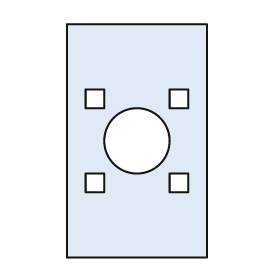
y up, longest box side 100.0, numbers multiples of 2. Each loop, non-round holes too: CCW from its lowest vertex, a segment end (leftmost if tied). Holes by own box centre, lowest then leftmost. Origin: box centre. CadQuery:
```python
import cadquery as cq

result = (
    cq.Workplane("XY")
    .moveTo(-30.0, -50.0)
    .lineTo(30.0, -50.0)
    .lineTo(30.0, 50.0)
    .lineTo(-30.0, 50.0)
    .close()
    .moveTo(-22.0, -22.0)
    .lineTo(-14.0, -22.0)
    .lineTo(-14.0, -14.0)
    .lineTo(-22.0, -14.0)
    .close()
    .moveTo(14.0, -22.0)
    .lineTo(22.0, -22.0)
    .lineTo(22.0, -14.0)
    .lineTo(14.0, -14.0)
    .close()
    .moveTo(0.0, 0.0)
    .circle(14.0)
    .moveTo(-22.0, 14.0)
    .lineTo(-14.0, 14.0)
    .lineTo(-14.0, 22.0)
    .lineTo(-22.0, 22.0)
    .close()
    .moveTo(14.0, 14.0)
    .lineTo(22.0, 14.0)
    .lineTo(22.0, 22.0)
    .lineTo(14.0, 22.0)
    .close()
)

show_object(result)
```